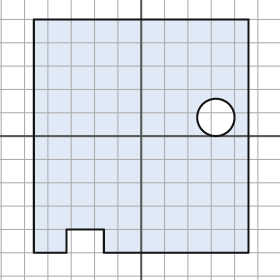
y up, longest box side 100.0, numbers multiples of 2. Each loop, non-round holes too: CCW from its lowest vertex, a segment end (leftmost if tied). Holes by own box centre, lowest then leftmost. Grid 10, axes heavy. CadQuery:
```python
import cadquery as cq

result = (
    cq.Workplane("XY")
    .moveTo(-46.0, -50.0)
    .lineTo(-32.0, -50.0)
    .lineTo(-32.0, -40.0)
    .lineTo(-16.0, -40.0)
    .lineTo(-16.0, -50.0)
    .lineTo(46.0, -50.0)
    .lineTo(46.0, 50.0)
    .lineTo(-46.0, 50.0)
    .close()
    .moveTo(32.0, 8.0)
    .circle(8.0)
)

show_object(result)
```